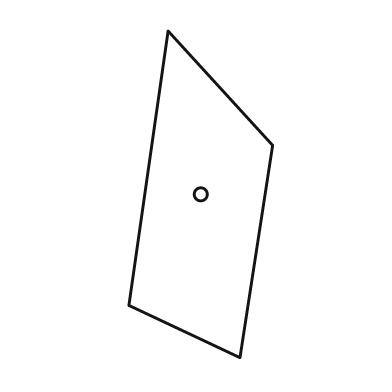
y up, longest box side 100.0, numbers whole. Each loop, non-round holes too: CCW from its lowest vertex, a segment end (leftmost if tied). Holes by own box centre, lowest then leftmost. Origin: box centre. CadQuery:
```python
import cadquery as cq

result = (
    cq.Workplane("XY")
    .moveTo(12.0, -50.0)
    .lineTo(22.0, 15.0)
    .lineTo(-10.0, 50.0)
    .lineTo(-22.0, -34.0)
    .close()
    .moveTo(0.0, 0.0)
    .circle(2.0)
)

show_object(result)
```